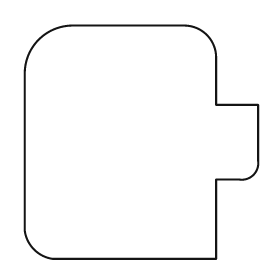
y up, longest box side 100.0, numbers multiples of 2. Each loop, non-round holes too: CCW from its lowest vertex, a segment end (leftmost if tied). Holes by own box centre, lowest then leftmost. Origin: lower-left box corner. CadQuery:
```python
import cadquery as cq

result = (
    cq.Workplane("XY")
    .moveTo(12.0, 0.0)
    .lineTo(82.0, 0.0)
    .lineTo(82.0, 34.0)
    .lineTo(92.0, 34.0)
    .threePointArc((98.0, 36.0), (100.0, 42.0))
    .lineTo(100.0, 66.0)
    .lineTo(82.0, 66.0)
    .lineTo(82.0, 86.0)
    .threePointArc((78.0, 96.0), (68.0, 100.0))
    .lineTo(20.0, 100.0)
    .threePointArc((6.0, 94.0), (0.0, 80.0))
    .lineTo(0.0, 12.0)
    .threePointArc((4.0, 4.0), (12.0, 0.0))
    .close()
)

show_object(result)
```